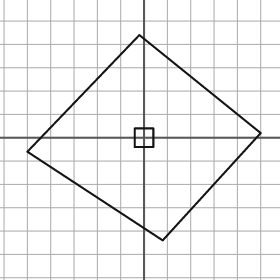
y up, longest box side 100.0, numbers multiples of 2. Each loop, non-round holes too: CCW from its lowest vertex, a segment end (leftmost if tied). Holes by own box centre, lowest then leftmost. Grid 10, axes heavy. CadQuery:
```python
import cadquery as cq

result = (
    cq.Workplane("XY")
    .moveTo(8.0, -44.0)
    .lineTo(50.0, 2.0)
    .lineTo(-2.0, 44.0)
    .lineTo(-50.0, -6.0)
    .close()
    .moveTo(-4.0, -4.0)
    .lineTo(4.0, -4.0)
    .lineTo(4.0, 4.0)
    .lineTo(-4.0, 4.0)
    .close()
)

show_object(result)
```